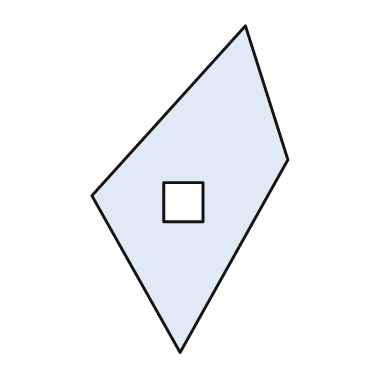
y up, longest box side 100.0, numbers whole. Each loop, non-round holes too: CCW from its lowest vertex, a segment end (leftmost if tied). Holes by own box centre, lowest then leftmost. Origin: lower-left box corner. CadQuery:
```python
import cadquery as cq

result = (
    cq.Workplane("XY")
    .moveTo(27.0, 0.0)
    .lineTo(60.0, 59.0)
    .lineTo(47.0, 100.0)
    .lineTo(0.0, 48.0)
    .close()
    .moveTo(22.0, 40.0)
    .lineTo(34.0, 40.0)
    .lineTo(34.0, 52.0)
    .lineTo(22.0, 52.0)
    .close()
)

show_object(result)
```